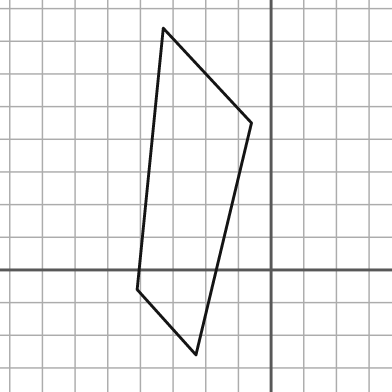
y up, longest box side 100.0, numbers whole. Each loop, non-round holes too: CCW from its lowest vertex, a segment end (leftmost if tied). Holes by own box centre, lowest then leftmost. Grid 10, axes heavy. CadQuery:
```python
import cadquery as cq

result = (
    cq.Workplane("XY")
    .moveTo(-23.0, -26.0)
    .lineTo(-6.0, 45.0)
    .lineTo(-33.0, 74.0)
    .lineTo(-41.0, -6.0)
    .close()
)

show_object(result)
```